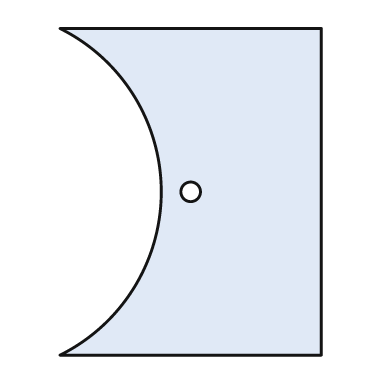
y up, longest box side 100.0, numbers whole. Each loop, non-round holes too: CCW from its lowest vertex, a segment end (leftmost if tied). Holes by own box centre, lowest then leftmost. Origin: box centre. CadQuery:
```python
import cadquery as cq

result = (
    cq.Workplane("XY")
    .moveTo(-40.0, -50.0)
    .lineTo(40.0, -50.0)
    .lineTo(40.0, 50.0)
    .lineTo(-40.0, 50.0)
    .threePointArc((-9.0, 0.0), (-40.0, -50.0))
    .close()
    .moveTo(0.0, 0.0)
    .circle(3.0)
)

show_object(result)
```